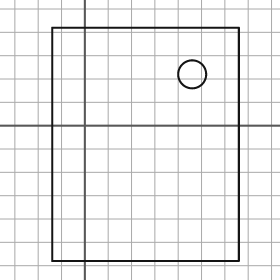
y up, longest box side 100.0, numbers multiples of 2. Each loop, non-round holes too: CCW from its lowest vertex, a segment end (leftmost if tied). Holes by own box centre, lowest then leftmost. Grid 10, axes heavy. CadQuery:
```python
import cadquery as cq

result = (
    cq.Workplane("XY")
    .moveTo(-14.0, -58.0)
    .lineTo(66.0, -58.0)
    .lineTo(66.0, 42.0)
    .lineTo(-14.0, 42.0)
    .close()
    .moveTo(46.0, 22.0)
    .circle(6.0)
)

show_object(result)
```